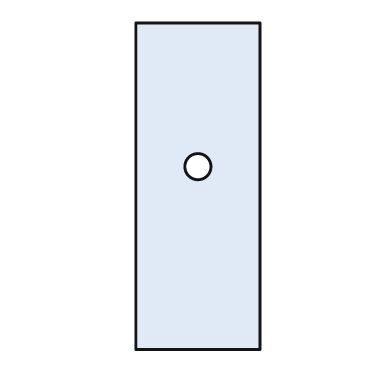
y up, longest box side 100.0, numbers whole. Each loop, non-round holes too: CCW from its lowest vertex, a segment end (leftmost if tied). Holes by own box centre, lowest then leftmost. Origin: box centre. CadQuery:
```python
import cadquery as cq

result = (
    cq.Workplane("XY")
    .moveTo(-19.0, -50.0)
    .lineTo(19.0, -50.0)
    .lineTo(19.0, 50.0)
    .lineTo(-19.0, 50.0)
    .close()
    .moveTo(0.0, 6.0)
    .circle(4.0)
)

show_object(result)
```